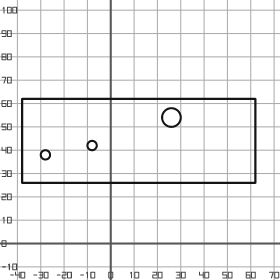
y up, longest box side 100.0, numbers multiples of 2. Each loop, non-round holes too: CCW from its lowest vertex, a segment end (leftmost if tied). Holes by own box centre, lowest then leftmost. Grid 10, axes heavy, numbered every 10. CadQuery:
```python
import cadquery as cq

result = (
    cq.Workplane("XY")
    .moveTo(-38.0, 26.0)
    .lineTo(62.0, 26.0)
    .lineTo(62.0, 62.0)
    .lineTo(-38.0, 62.0)
    .close()
    .moveTo(-28.0, 38.0)
    .circle(2.0)
    .moveTo(-8.0, 42.0)
    .circle(2.0)
    .moveTo(26.0, 54.0)
    .circle(4.0)
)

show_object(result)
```